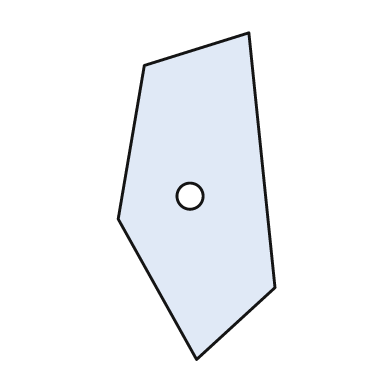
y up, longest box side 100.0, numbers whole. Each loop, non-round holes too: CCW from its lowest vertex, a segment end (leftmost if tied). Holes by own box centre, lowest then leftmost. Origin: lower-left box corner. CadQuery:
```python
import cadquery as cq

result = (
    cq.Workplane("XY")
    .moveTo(24.0, 0.0)
    .lineTo(48.0, 22.0)
    .lineTo(40.0, 100.0)
    .lineTo(8.0, 90.0)
    .lineTo(0.0, 43.0)
    .close()
    .moveTo(22.0, 50.0)
    .circle(4.0)
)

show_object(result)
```